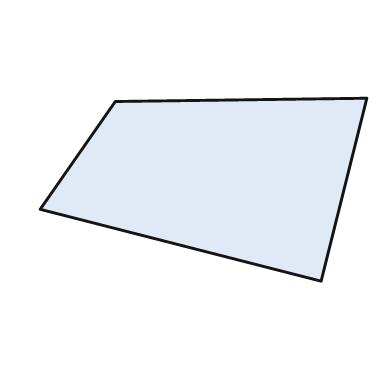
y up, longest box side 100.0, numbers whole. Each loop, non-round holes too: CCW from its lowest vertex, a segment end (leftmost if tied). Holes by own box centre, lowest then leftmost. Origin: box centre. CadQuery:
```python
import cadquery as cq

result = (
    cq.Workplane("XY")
    .moveTo(36.0, -28.0)
    .lineTo(50.0, 28.0)
    .lineTo(-27.0, 27.0)
    .lineTo(-50.0, -6.0)
    .close()
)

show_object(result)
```